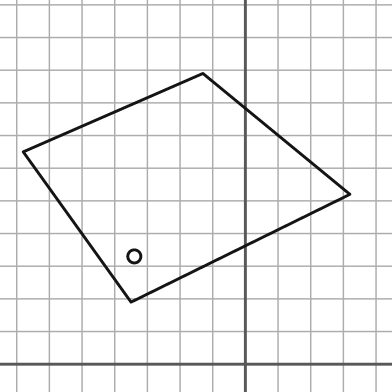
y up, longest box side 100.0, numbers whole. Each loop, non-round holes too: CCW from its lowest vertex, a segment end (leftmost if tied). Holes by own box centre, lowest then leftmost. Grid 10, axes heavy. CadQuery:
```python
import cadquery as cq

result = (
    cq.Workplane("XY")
    .moveTo(-35.0, 19.0)
    .lineTo(32.0, 52.0)
    .lineTo(-13.0, 89.0)
    .lineTo(-68.0, 65.0)
    .close()
    .moveTo(-34.0, 33.0)
    .circle(2.0)
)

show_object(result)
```